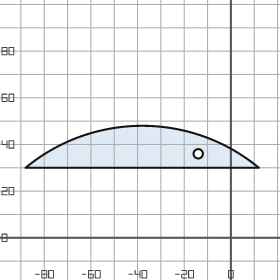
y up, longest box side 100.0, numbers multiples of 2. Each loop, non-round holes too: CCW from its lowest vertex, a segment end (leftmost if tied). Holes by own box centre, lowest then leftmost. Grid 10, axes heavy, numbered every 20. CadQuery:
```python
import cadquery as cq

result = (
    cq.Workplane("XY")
    .moveTo(-88.0, 30.0)
    .lineTo(12.0, 30.0)
    .threePointArc((-38.0, 48.0), (-88.0, 30.0))
    .close()
    .moveTo(-14.0, 36.0)
    .circle(2.0)
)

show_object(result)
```